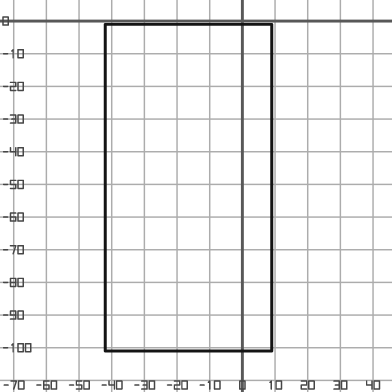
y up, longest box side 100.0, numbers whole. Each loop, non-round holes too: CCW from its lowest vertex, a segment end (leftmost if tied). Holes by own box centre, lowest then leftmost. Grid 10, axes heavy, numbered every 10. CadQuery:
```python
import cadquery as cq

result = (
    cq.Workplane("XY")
    .moveTo(-42.0, -101.0)
    .lineTo(9.0, -101.0)
    .lineTo(9.0, -1.0)
    .lineTo(-42.0, -1.0)
    .close()
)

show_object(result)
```